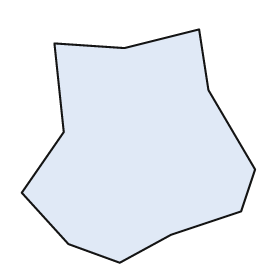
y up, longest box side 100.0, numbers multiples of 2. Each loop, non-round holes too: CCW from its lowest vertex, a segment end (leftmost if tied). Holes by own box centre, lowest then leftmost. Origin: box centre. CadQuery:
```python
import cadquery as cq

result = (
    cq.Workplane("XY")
    .moveTo(-8.0, -50.0)
    .lineTo(14.0, -38.0)
    .lineTo(44.0, -28.0)
    .lineTo(50.0, -10.0)
    .lineTo(30.0, 24.0)
    .lineTo(26.0, 50.0)
    .lineTo(-6.0, 42.0)
    .lineTo(-36.0, 44.0)
    .lineTo(-32.0, 6.0)
    .lineTo(-50.0, -20.0)
    .lineTo(-30.0, -42.0)
    .close()
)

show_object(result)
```